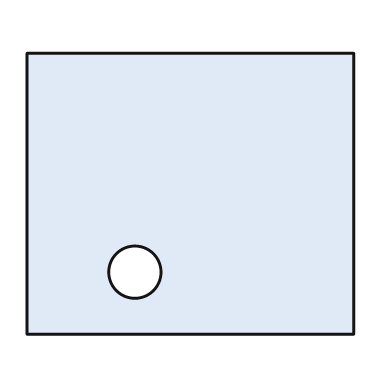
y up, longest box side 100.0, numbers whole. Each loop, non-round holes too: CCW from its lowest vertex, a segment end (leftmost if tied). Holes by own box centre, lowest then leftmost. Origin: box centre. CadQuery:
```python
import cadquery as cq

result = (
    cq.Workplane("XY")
    .moveTo(-50.0, -43.0)
    .lineTo(50.0, -43.0)
    .lineTo(50.0, 43.0)
    .lineTo(-50.0, 43.0)
    .close()
    .moveTo(-17.0, -24.0)
    .circle(8.0)
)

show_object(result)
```